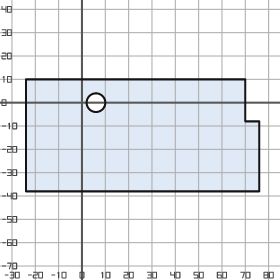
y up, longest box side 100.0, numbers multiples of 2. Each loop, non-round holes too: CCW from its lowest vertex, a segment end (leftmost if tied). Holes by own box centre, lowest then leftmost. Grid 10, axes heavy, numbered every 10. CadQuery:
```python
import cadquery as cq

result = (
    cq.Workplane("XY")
    .moveTo(-24.0, -38.0)
    .lineTo(76.0, -38.0)
    .lineTo(76.0, -8.0)
    .lineTo(70.0, -8.0)
    .lineTo(70.0, 10.0)
    .lineTo(-24.0, 10.0)
    .close()
    .moveTo(6.0, 0.0)
    .circle(4.0)
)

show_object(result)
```